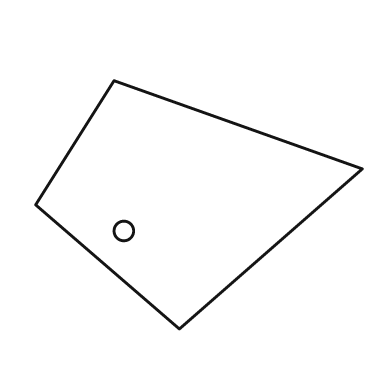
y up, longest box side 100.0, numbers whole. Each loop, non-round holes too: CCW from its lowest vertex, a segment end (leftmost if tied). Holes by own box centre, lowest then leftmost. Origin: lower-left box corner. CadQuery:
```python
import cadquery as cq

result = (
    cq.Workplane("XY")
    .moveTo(44.0, 0.0)
    .lineTo(100.0, 49.0)
    .lineTo(24.0, 76.0)
    .lineTo(0.0, 38.0)
    .close()
    .moveTo(27.0, 30.0)
    .circle(3.0)
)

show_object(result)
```